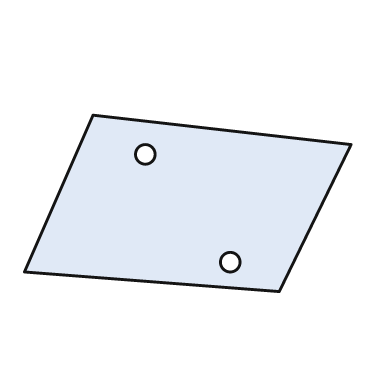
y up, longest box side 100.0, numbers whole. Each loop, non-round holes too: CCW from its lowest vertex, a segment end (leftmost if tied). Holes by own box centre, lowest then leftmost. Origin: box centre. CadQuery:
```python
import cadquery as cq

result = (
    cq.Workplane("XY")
    .moveTo(28.0, -27.0)
    .lineTo(50.0, 18.0)
    .lineTo(-29.0, 27.0)
    .lineTo(-50.0, -21.0)
    .close()
    .moveTo(13.0, -18.0)
    .circle(3.0)
    .moveTo(-13.0, 15.0)
    .circle(3.0)
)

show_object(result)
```